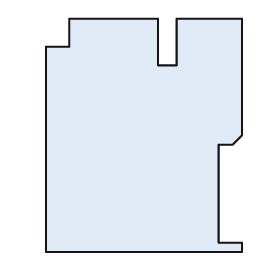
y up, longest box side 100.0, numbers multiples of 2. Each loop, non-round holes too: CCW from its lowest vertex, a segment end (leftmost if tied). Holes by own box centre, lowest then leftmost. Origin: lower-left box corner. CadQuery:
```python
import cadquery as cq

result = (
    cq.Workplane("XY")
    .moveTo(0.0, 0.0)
    .lineTo(84.0, 0.0)
    .lineTo(84.0, 4.0)
    .lineTo(74.0, 4.0)
    .lineTo(74.0, 46.0)
    .lineTo(80.0, 46.0)
    .lineTo(84.0, 50.0)
    .lineTo(84.0, 100.0)
    .lineTo(56.0, 100.0)
    .lineTo(56.0, 80.0)
    .lineTo(48.0, 80.0)
    .lineTo(48.0, 100.0)
    .lineTo(10.0, 100.0)
    .lineTo(10.0, 88.0)
    .lineTo(0.0, 88.0)
    .close()
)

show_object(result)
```